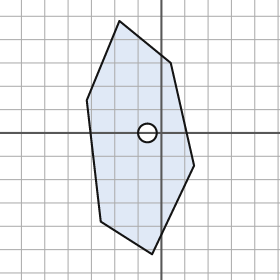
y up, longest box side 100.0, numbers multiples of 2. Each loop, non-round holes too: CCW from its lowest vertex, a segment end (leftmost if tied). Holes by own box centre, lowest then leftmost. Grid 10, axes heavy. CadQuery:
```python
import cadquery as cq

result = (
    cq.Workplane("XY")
    .moveTo(-4.0, -52.0)
    .lineTo(14.0, -14.0)
    .lineTo(4.0, 30.0)
    .lineTo(-18.0, 48.0)
    .lineTo(-32.0, 14.0)
    .lineTo(-26.0, -38.0)
    .close()
    .moveTo(-6.0, 0.0)
    .circle(4.0)
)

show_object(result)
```